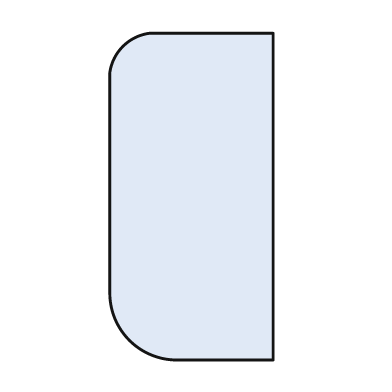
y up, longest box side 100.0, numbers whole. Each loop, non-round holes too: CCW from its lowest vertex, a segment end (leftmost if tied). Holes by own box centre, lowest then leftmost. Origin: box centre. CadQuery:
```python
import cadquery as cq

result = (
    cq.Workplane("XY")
    .moveTo(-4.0, -50.0)
    .lineTo(25.0, -50.0)
    .lineTo(25.0, 50.0)
    .lineTo(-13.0, 50.0)
    .threePointArc((-21.0, 46.0), (-25.0, 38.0))
    .lineTo(-25.0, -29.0)
    .threePointArc((-19.0, -44.0), (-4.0, -50.0))
    .close()
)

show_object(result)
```